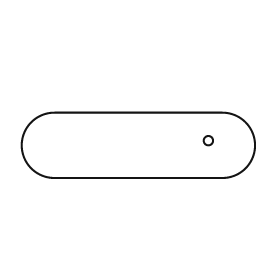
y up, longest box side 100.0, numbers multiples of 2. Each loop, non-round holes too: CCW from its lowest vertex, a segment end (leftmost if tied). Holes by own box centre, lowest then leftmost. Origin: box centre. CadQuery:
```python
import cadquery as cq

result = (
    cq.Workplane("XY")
    .moveTo(-36.0, -14.0)
    .lineTo(36.0, -14.0)
    .threePointArc((50.0, 0.0), (36.0, 14.0))
    .lineTo(-36.0, 14.0)
    .threePointArc((-50.0, 0.0), (-36.0, -14.0))
    .close()
    .moveTo(30.0, 2.0)
    .circle(2.0)
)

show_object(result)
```